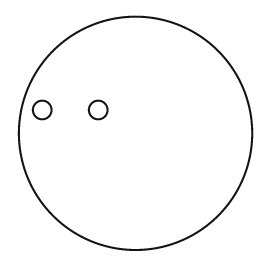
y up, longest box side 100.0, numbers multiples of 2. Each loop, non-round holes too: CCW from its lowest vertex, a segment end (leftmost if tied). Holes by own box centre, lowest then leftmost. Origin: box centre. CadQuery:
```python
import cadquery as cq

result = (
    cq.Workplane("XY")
    .moveTo(0.0, 0.0)
    .circle(50.0)
    .moveTo(-40.0, 10.0)
    .circle(4.0)
    .moveTo(-16.0, 10.0)
    .circle(4.0)
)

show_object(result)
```